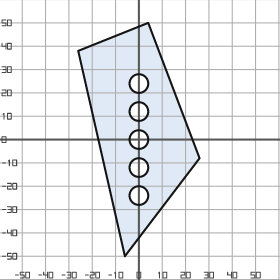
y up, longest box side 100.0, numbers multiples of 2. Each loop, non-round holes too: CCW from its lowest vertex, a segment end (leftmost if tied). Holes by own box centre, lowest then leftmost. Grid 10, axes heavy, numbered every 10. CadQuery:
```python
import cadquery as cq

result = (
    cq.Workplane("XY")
    .moveTo(-6.0, -50.0)
    .lineTo(26.0, -8.0)
    .lineTo(4.0, 50.0)
    .lineTo(-26.0, 38.0)
    .close()
    .moveTo(0.0, -24.0)
    .circle(4.0)
    .moveTo(0.0, -12.0)
    .circle(4.0)
    .moveTo(0.0, 0.0)
    .circle(4.0)
    .moveTo(0.0, 12.0)
    .circle(4.0)
    .moveTo(0.0, 24.0)
    .circle(4.0)
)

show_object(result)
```